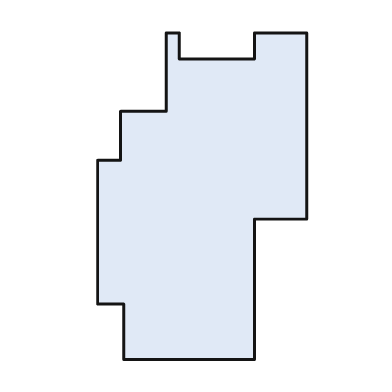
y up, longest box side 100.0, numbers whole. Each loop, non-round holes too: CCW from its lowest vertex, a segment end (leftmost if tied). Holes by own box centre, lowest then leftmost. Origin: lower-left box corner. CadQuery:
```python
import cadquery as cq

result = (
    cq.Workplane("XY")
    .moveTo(8.0, 0.0)
    .lineTo(48.0, 0.0)
    .lineTo(48.0, 43.0)
    .lineTo(64.0, 43.0)
    .lineTo(64.0, 100.0)
    .lineTo(48.0, 100.0)
    .lineTo(48.0, 92.0)
    .lineTo(25.0, 92.0)
    .lineTo(25.0, 100.0)
    .lineTo(21.0, 100.0)
    .lineTo(21.0, 76.0)
    .lineTo(7.0, 76.0)
    .lineTo(7.0, 61.0)
    .lineTo(0.0, 61.0)
    .lineTo(0.0, 17.0)
    .lineTo(8.0, 17.0)
    .close()
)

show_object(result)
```